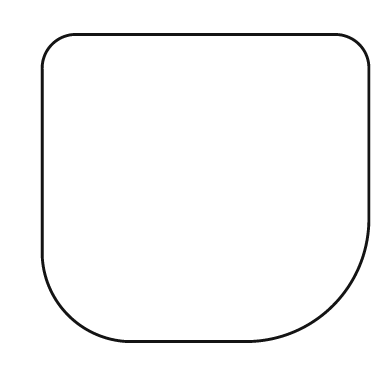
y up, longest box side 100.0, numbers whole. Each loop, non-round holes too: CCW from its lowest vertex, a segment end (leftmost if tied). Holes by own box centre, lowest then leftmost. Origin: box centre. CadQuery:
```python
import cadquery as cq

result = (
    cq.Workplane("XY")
    .moveTo(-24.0, -47.0)
    .lineTo(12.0, -47.0)
    .threePointArc((39.0, -36.0), (50.0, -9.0))
    .lineTo(50.0, 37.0)
    .threePointArc((47.0, 44.0), (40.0, 47.0))
    .lineTo(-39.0, 47.0)
    .threePointArc((-47.0, 44.0), (-50.0, 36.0))
    .lineTo(-50.0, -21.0)
    .threePointArc((-42.0, -39.0), (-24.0, -47.0))
    .close()
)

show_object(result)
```